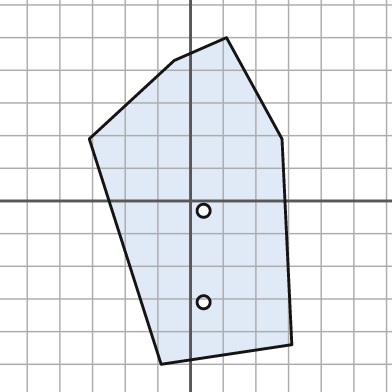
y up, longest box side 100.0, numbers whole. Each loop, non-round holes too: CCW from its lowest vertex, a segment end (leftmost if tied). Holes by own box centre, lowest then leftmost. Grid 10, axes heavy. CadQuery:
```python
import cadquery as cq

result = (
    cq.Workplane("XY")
    .moveTo(-9.0, -50.0)
    .lineTo(31.0, -44.0)
    .lineTo(28.0, 19.0)
    .lineTo(11.0, 50.0)
    .lineTo(-5.0, 43.0)
    .lineTo(-31.0, 19.0)
    .close()
    .moveTo(4.0, -31.0)
    .circle(2.0)
    .moveTo(4.0, -3.0)
    .circle(2.0)
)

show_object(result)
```